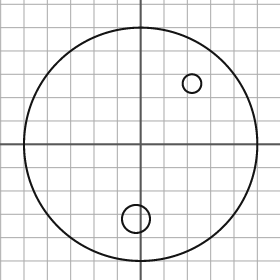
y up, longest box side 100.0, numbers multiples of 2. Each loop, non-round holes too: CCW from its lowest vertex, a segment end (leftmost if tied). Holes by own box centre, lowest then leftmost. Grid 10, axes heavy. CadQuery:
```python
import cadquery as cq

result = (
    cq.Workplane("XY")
    .moveTo(0.0, 0.0)
    .circle(50.0)
    .moveTo(-2.0, -32.0)
    .circle(6.0)
    .moveTo(22.0, 26.0)
    .circle(4.0)
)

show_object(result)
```